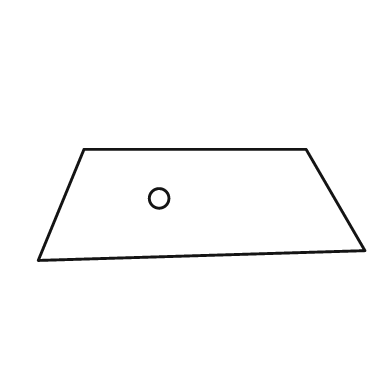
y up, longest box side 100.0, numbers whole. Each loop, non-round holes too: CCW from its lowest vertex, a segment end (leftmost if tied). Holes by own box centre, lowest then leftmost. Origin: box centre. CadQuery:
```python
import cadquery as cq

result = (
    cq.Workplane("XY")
    .moveTo(-50.0, -17.0)
    .lineTo(50.0, -14.0)
    .lineTo(32.0, 17.0)
    .lineTo(-36.0, 17.0)
    .close()
    .moveTo(-13.0, 2.0)
    .circle(3.0)
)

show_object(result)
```